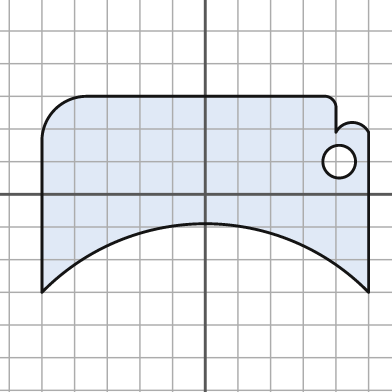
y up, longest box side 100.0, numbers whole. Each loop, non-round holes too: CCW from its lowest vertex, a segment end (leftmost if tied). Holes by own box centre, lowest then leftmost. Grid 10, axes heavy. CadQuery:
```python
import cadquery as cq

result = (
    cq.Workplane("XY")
    .moveTo(-50.0, -30.0)
    .threePointArc((0.0, -9.0), (50.0, -30.0))
    .lineTo(50.0, 19.0)
    .threePointArc((45.0, 22.0), (40.0, 19.0))
    .lineTo(40.0, 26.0)
    .threePointArc((39.0, 29.0), (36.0, 30.0))
    .lineTo(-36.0, 30.0)
    .threePointArc((-46.0, 26.0), (-50.0, 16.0))
    .close()
    .moveTo(41.0, 10.0)
    .circle(5.0)
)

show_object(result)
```